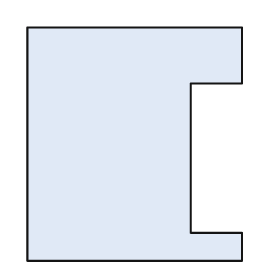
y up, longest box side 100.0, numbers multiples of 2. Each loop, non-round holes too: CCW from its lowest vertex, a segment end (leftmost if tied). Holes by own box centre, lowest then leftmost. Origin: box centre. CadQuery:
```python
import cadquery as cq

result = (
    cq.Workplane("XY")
    .moveTo(-46.0, -50.0)
    .lineTo(46.0, -50.0)
    .lineTo(46.0, -38.0)
    .lineTo(24.0, -38.0)
    .lineTo(24.0, 26.0)
    .lineTo(46.0, 26.0)
    .lineTo(46.0, 50.0)
    .lineTo(-46.0, 50.0)
    .close()
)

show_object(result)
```